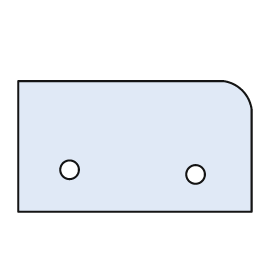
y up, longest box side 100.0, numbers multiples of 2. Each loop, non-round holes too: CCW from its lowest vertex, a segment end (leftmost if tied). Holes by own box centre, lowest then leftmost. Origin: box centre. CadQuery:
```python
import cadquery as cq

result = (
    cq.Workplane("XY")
    .moveTo(-50.0, -28.0)
    .lineTo(50.0, -28.0)
    .lineTo(50.0, 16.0)
    .threePointArc((46.0, 24.0), (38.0, 28.0))
    .lineTo(-50.0, 28.0)
    .close()
    .moveTo(26.0, -12.0)
    .circle(4.0)
    .moveTo(-28.0, -10.0)
    .circle(4.0)
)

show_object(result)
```